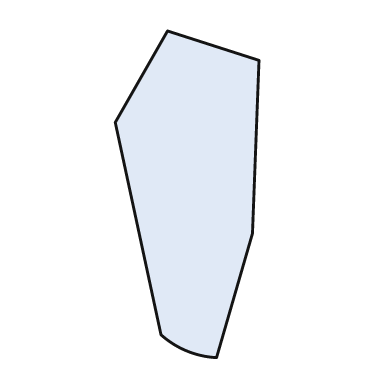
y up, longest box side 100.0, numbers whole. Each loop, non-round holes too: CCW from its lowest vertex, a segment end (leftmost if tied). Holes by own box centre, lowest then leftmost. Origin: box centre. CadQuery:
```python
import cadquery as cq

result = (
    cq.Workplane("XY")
    .moveTo(9.0, -50.0)
    .lineTo(20.0, -12.0)
    .lineTo(22.0, 41.0)
    .lineTo(-6.0, 50.0)
    .lineTo(-22.0, 22.0)
    .lineTo(-8.0, -43.0)
    .threePointArc((0.0, -48.0), (9.0, -50.0))
    .close()
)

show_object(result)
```